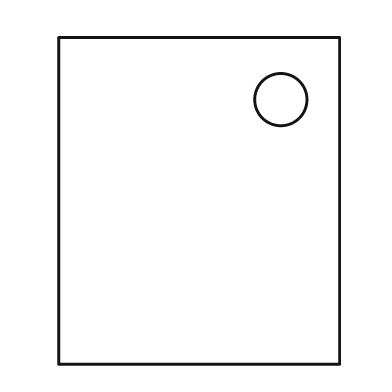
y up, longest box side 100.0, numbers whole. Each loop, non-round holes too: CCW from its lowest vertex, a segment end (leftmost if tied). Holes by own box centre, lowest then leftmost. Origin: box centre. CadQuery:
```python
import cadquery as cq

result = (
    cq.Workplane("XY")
    .moveTo(-43.0, -50.0)
    .lineTo(43.0, -50.0)
    .lineTo(43.0, 50.0)
    .lineTo(-43.0, 50.0)
    .close()
    .moveTo(25.0, 31.0)
    .circle(8.0)
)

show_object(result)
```